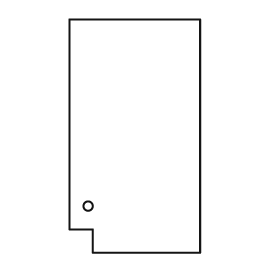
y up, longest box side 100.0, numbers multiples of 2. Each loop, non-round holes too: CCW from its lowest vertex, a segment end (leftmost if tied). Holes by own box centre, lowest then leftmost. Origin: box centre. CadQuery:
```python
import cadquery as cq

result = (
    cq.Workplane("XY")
    .moveTo(-18.0, -50.0)
    .lineTo(28.0, -50.0)
    .lineTo(28.0, 50.0)
    .lineTo(-28.0, 50.0)
    .lineTo(-28.0, -40.0)
    .lineTo(-18.0, -40.0)
    .close()
    .moveTo(-20.0, -30.0)
    .circle(2.0)
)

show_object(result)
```